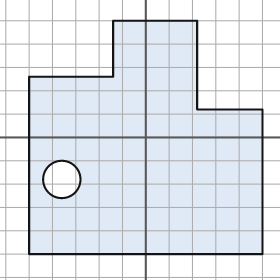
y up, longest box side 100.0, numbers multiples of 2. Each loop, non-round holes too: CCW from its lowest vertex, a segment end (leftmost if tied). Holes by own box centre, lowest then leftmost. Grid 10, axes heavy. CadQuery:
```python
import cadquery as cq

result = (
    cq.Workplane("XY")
    .moveTo(-50.0, -50.0)
    .lineTo(50.0, -50.0)
    .lineTo(50.0, 12.0)
    .lineTo(22.0, 12.0)
    .lineTo(22.0, 50.0)
    .lineTo(-14.0, 50.0)
    .lineTo(-14.0, 26.0)
    .lineTo(-50.0, 26.0)
    .close()
    .moveTo(-36.0, -18.0)
    .circle(8.0)
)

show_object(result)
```